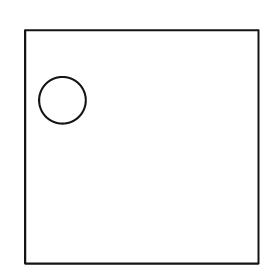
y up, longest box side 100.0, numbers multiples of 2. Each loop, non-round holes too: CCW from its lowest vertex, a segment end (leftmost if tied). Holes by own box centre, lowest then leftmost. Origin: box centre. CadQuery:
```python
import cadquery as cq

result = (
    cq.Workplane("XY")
    .moveTo(-50.0, -50.0)
    .lineTo(50.0, -50.0)
    .lineTo(50.0, 50.0)
    .lineTo(-50.0, 50.0)
    .close()
    .moveTo(-34.0, 20.0)
    .circle(10.0)
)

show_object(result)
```